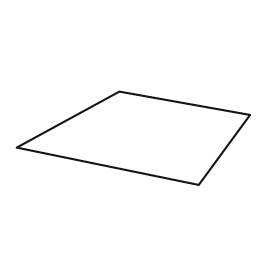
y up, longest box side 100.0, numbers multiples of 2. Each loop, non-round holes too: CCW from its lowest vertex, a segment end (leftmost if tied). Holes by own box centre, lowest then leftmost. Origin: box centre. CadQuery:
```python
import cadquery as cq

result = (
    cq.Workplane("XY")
    .moveTo(28.0, -20.0)
    .lineTo(50.0, 10.0)
    .lineTo(-6.0, 20.0)
    .lineTo(-50.0, -4.0)
    .close()
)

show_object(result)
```